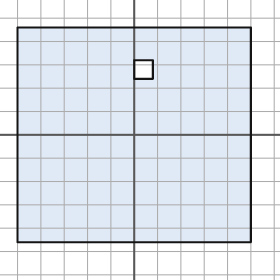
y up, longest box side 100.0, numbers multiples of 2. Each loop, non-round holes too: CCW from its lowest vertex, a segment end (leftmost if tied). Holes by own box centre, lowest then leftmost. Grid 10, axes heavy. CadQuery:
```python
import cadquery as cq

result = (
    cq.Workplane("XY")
    .moveTo(-50.0, -46.0)
    .lineTo(50.0, -46.0)
    .lineTo(50.0, 46.0)
    .lineTo(-50.0, 46.0)
    .close()
    .moveTo(0.0, 24.0)
    .lineTo(8.0, 24.0)
    .lineTo(8.0, 32.0)
    .lineTo(0.0, 32.0)
    .close()
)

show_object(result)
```